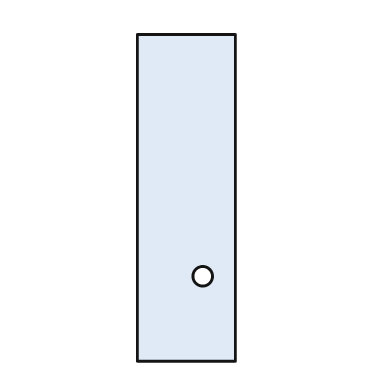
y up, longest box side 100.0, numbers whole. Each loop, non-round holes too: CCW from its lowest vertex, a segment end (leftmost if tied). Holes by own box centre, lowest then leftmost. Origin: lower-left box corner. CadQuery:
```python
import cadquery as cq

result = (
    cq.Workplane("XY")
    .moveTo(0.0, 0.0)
    .lineTo(30.0, 0.0)
    .lineTo(30.0, 100.0)
    .lineTo(0.0, 100.0)
    .close()
    .moveTo(20.0, 26.0)
    .circle(3.0)
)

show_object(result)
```